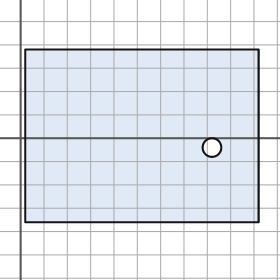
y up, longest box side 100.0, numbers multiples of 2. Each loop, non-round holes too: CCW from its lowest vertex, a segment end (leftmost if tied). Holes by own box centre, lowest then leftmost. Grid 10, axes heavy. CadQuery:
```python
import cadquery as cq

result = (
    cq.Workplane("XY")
    .moveTo(2.0, -36.0)
    .lineTo(102.0, -36.0)
    .lineTo(102.0, 38.0)
    .lineTo(2.0, 38.0)
    .close()
    .moveTo(82.0, -4.0)
    .circle(4.0)
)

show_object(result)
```